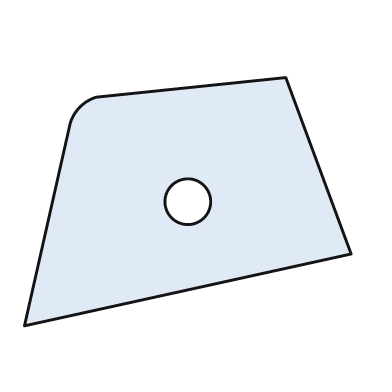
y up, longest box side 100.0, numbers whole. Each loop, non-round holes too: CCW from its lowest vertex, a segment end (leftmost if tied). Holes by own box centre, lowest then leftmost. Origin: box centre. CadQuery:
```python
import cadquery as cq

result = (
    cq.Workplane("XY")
    .moveTo(-50.0, -38.0)
    .lineTo(50.0, -16.0)
    .lineTo(30.0, 38.0)
    .lineTo(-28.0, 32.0)
    .threePointArc((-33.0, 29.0), (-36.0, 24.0))
    .close()
    .moveTo(0.0, 0.0)
    .circle(7.0)
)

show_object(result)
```